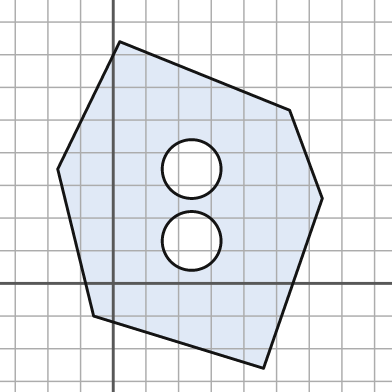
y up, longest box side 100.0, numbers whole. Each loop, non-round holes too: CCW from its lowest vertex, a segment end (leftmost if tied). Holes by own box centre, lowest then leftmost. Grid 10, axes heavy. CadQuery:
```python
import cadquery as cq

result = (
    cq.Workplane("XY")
    .moveTo(46.0, -26.0)
    .lineTo(64.0, 26.0)
    .lineTo(54.0, 53.0)
    .lineTo(2.0, 74.0)
    .lineTo(-17.0, 35.0)
    .lineTo(-6.0, -10.0)
    .close()
    .moveTo(24.0, 13.0)
    .circle(9.0)
    .moveTo(24.0, 35.0)
    .circle(9.0)
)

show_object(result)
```